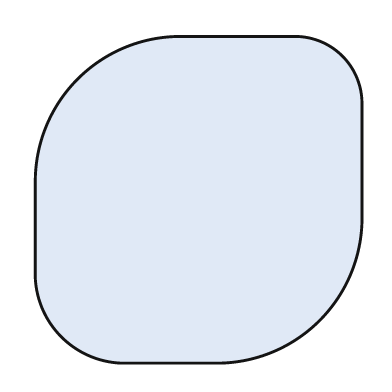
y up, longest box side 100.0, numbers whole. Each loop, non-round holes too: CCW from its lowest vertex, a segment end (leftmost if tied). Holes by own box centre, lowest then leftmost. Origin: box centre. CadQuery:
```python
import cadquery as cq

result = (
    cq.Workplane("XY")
    .moveTo(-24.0, -50.0)
    .lineTo(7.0, -50.0)
    .threePointArc((37.0, -37.0), (50.0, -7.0))
    .lineTo(50.0, 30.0)
    .threePointArc((44.0, 44.0), (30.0, 50.0))
    .lineTo(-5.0, 50.0)
    .threePointArc((-37.0, 37.0), (-50.0, 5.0))
    .lineTo(-50.0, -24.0)
    .threePointArc((-42.0, -42.0), (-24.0, -50.0))
    .close()
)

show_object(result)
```